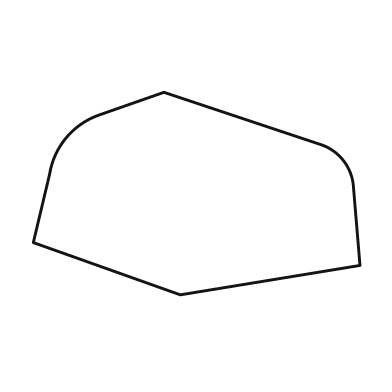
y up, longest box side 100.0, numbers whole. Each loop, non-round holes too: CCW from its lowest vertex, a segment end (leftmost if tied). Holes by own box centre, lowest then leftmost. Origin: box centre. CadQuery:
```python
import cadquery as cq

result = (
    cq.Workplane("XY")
    .moveTo(-5.0, -31.0)
    .lineTo(50.0, -22.0)
    .lineTo(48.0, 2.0)
    .threePointArc((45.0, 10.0), (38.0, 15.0))
    .lineTo(-10.0, 31.0)
    .lineTo(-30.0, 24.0)
    .threePointArc((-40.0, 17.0), (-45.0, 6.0))
    .lineTo(-50.0, -15.0)
    .close()
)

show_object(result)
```